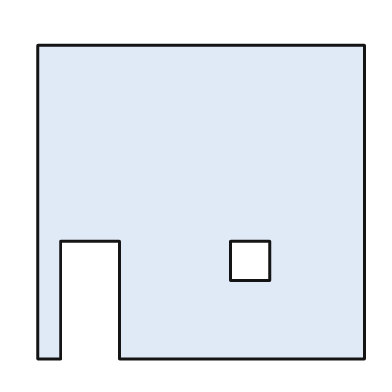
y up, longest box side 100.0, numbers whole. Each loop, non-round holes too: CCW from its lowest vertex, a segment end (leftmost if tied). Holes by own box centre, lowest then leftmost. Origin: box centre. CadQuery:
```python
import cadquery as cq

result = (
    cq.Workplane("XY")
    .moveTo(-50.0, -48.0)
    .lineTo(-43.0, -48.0)
    .lineTo(-43.0, -12.0)
    .lineTo(-25.0, -12.0)
    .lineTo(-25.0, -48.0)
    .lineTo(50.0, -48.0)
    .lineTo(50.0, 48.0)
    .lineTo(-50.0, 48.0)
    .close()
    .moveTo(9.0, -24.0)
    .lineTo(21.0, -24.0)
    .lineTo(21.0, -12.0)
    .lineTo(9.0, -12.0)
    .close()
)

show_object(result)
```